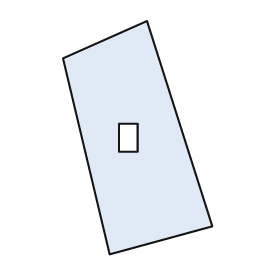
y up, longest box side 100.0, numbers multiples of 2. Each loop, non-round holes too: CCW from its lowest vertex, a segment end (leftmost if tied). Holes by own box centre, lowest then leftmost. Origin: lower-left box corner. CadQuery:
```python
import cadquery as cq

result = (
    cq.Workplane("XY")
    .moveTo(20.0, 0.0)
    .lineTo(64.0, 12.0)
    .lineTo(36.0, 100.0)
    .lineTo(0.0, 84.0)
    .close()
    .moveTo(24.0, 44.0)
    .lineTo(32.0, 44.0)
    .lineTo(32.0, 56.0)
    .lineTo(24.0, 56.0)
    .close()
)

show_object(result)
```